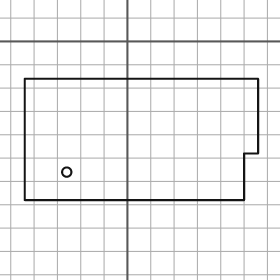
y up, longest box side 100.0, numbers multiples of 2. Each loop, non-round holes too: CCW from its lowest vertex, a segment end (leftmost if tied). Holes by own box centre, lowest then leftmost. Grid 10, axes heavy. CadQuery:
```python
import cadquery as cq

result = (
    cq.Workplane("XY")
    .moveTo(-44.0, -68.0)
    .lineTo(50.0, -68.0)
    .lineTo(50.0, -48.0)
    .lineTo(56.0, -48.0)
    .lineTo(56.0, -16.0)
    .lineTo(-44.0, -16.0)
    .close()
    .moveTo(-26.0, -56.0)
    .circle(2.0)
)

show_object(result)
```